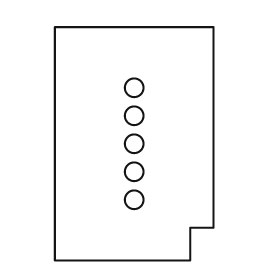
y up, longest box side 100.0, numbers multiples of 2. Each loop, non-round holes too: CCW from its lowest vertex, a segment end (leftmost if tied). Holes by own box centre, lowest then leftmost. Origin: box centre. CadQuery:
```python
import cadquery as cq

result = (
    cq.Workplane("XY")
    .moveTo(-34.0, -50.0)
    .lineTo(24.0, -50.0)
    .lineTo(24.0, -36.0)
    .lineTo(34.0, -36.0)
    .lineTo(34.0, 50.0)
    .lineTo(-34.0, 50.0)
    .close()
    .moveTo(0.0, -24.0)
    .circle(4.0)
    .moveTo(0.0, -12.0)
    .circle(4.0)
    .moveTo(0.0, 0.0)
    .circle(4.0)
    .moveTo(0.0, 12.0)
    .circle(4.0)
    .moveTo(0.0, 24.0)
    .circle(4.0)
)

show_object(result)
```